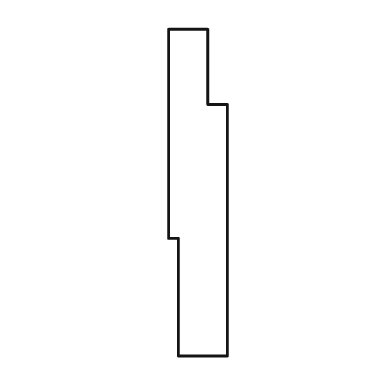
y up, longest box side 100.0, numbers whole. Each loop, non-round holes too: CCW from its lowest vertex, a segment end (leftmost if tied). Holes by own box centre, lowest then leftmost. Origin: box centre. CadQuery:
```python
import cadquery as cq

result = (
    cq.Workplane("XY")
    .moveTo(-6.0, -50.0)
    .lineTo(9.0, -50.0)
    .lineTo(9.0, 27.0)
    .lineTo(3.0, 27.0)
    .lineTo(3.0, 50.0)
    .lineTo(-9.0, 50.0)
    .lineTo(-9.0, -14.0)
    .lineTo(-6.0, -14.0)
    .close()
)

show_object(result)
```